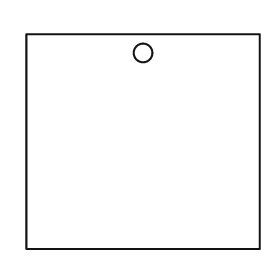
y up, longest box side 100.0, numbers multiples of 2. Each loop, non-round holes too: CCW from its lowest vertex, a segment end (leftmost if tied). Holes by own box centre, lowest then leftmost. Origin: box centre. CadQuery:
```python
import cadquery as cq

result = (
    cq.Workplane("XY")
    .moveTo(-50.0, -46.0)
    .lineTo(50.0, -46.0)
    .lineTo(50.0, 46.0)
    .lineTo(-50.0, 46.0)
    .close()
    .moveTo(0.0, 38.0)
    .circle(4.0)
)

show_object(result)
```